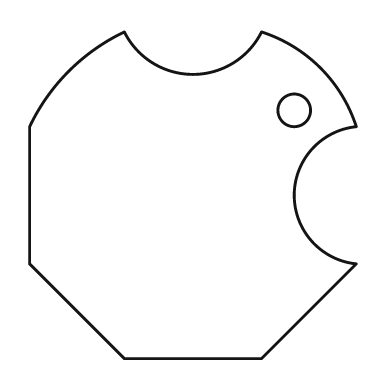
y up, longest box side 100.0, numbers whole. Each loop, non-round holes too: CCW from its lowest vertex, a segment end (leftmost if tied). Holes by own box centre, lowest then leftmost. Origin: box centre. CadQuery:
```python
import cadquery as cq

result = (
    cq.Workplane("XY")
    .moveTo(-21.0, -50.0)
    .lineTo(21.0, -50.0)
    .lineTo(50.0, -21.0)
    .threePointArc((31.0, 0.0), (50.0, 21.0))
    .threePointArc((39.0, 39.0), (21.0, 50.0))
    .threePointArc((0.0, 37.0), (-21.0, 50.0))
    .threePointArc((-38.0, 38.0), (-50.0, 21.0))
    .lineTo(-50.0, -21.0)
    .close()
    .moveTo(31.0, 26.0)
    .circle(5.0)
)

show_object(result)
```